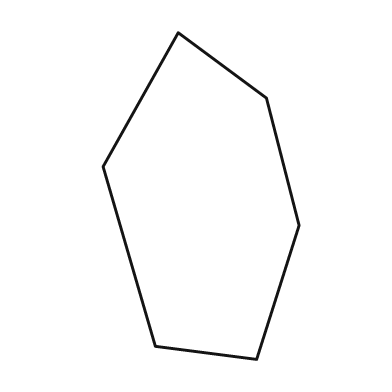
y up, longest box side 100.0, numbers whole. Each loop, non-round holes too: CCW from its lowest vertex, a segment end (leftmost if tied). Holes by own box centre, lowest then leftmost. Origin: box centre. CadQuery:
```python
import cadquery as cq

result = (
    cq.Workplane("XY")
    .moveTo(17.0, -50.0)
    .lineTo(30.0, -9.0)
    .lineTo(20.0, 30.0)
    .lineTo(-7.0, 50.0)
    .lineTo(-30.0, 9.0)
    .lineTo(-14.0, -46.0)
    .close()
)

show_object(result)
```